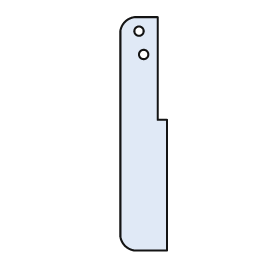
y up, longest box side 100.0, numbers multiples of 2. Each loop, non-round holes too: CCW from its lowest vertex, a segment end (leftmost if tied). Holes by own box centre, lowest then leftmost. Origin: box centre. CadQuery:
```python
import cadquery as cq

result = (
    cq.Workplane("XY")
    .moveTo(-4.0, -50.0)
    .lineTo(10.0, -50.0)
    .lineTo(10.0, 6.0)
    .lineTo(6.0, 6.0)
    .lineTo(6.0, 50.0)
    .lineTo(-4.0, 50.0)
    .threePointArc((-8.0, 48.0), (-10.0, 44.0))
    .lineTo(-10.0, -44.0)
    .threePointArc((-8.0, -48.0), (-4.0, -50.0))
    .close()
    .moveTo(0.0, 34.0)
    .circle(2.0)
    .moveTo(-2.0, 44.0)
    .circle(2.0)
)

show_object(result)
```